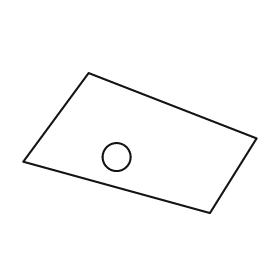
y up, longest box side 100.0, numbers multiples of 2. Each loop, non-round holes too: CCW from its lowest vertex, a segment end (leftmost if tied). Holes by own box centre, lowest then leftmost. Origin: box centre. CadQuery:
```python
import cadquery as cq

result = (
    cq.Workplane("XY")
    .moveTo(30.0, -30.0)
    .lineTo(50.0, 2.0)
    .lineTo(-22.0, 30.0)
    .lineTo(-50.0, -8.0)
    .close()
    .moveTo(-10.0, -6.0)
    .circle(6.0)
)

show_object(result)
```